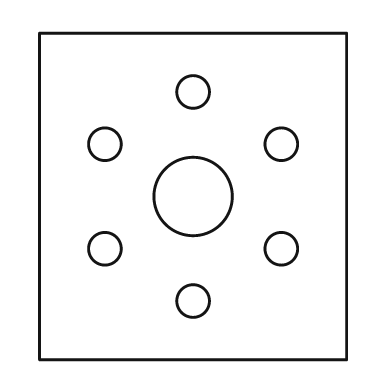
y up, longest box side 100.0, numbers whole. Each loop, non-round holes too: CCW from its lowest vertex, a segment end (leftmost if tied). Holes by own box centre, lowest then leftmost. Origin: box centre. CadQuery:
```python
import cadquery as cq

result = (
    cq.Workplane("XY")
    .moveTo(-47.0, -50.0)
    .lineTo(47.0, -50.0)
    .lineTo(47.0, 50.0)
    .lineTo(-47.0, 50.0)
    .close()
    .moveTo(0.0, -32.0)
    .circle(5.0)
    .moveTo(-27.0, -16.0)
    .circle(5.0)
    .moveTo(27.0, -16.0)
    .circle(5.0)
    .moveTo(0.0, 0.0)
    .circle(12.0)
    .moveTo(-27.0, 16.0)
    .circle(5.0)
    .moveTo(27.0, 16.0)
    .circle(5.0)
    .moveTo(0.0, 32.0)
    .circle(5.0)
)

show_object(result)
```